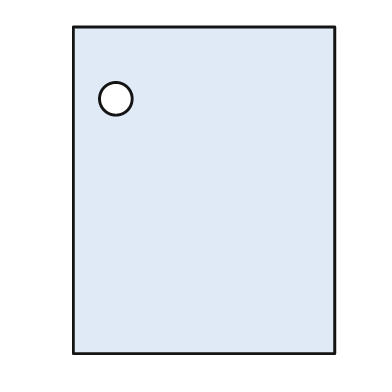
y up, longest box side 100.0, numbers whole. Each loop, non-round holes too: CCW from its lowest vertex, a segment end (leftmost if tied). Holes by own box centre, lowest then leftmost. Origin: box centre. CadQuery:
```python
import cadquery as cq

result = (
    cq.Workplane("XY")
    .moveTo(-40.0, -50.0)
    .lineTo(40.0, -50.0)
    .lineTo(40.0, 50.0)
    .lineTo(-40.0, 50.0)
    .close()
    .moveTo(-27.0, 28.0)
    .circle(5.0)
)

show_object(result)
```